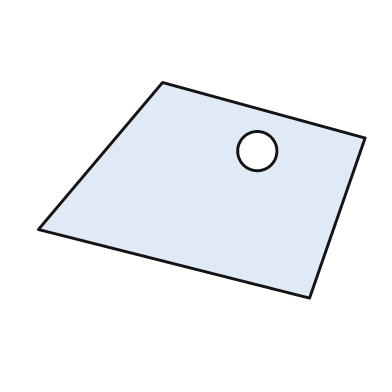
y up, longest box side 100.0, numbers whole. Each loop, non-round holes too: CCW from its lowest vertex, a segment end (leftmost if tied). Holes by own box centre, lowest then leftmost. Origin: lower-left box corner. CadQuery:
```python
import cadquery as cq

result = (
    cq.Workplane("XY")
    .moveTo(83.0, 0.0)
    .lineTo(100.0, 49.0)
    .lineTo(38.0, 66.0)
    .lineTo(0.0, 21.0)
    .close()
    .moveTo(67.0, 45.0)
    .circle(6.0)
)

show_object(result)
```